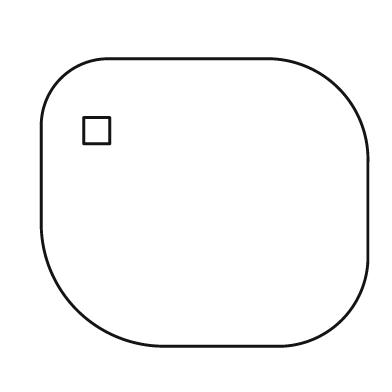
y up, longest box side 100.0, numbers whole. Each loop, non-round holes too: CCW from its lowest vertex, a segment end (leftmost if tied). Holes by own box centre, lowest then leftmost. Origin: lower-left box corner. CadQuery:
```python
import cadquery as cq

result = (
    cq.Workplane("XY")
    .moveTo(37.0, 0.0)
    .lineTo(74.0, 0.0)
    .threePointArc((92.0, 8.0), (100.0, 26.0))
    .lineTo(100.0, 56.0)
    .threePointArc((91.0, 79.0), (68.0, 88.0))
    .lineTo(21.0, 88.0)
    .threePointArc((6.0, 82.0), (0.0, 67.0))
    .lineTo(0.0, 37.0)
    .threePointArc((11.0, 11.0), (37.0, 0.0))
    .close()
    .moveTo(13.0, 62.0)
    .lineTo(21.0, 62.0)
    .lineTo(21.0, 70.0)
    .lineTo(13.0, 70.0)
    .close()
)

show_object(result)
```